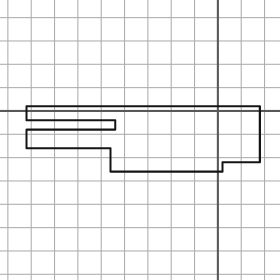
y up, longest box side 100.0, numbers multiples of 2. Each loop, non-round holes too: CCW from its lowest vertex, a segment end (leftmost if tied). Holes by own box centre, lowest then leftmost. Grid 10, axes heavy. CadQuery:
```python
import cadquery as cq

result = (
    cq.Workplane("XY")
    .moveTo(-46.0, -26.0)
    .lineTo(2.0, -26.0)
    .lineTo(2.0, -22.0)
    .lineTo(18.0, -22.0)
    .lineTo(18.0, 2.0)
    .lineTo(-82.0, 2.0)
    .lineTo(-82.0, -4.0)
    .lineTo(-44.0, -4.0)
    .lineTo(-44.0, -8.0)
    .lineTo(-82.0, -8.0)
    .lineTo(-82.0, -16.0)
    .lineTo(-46.0, -16.0)
    .close()
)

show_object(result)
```